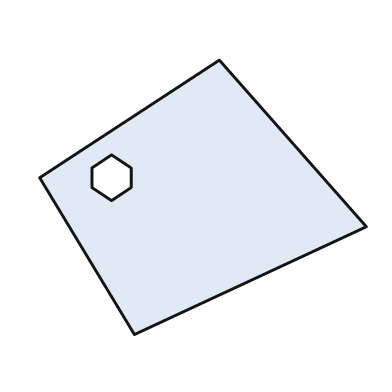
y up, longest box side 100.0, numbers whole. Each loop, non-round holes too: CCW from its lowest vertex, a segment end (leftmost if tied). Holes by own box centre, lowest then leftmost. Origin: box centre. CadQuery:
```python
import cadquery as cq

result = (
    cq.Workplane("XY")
    .moveTo(-21.0, -42.0)
    .lineTo(50.0, -9.0)
    .lineTo(5.0, 42.0)
    .lineTo(-50.0, 6.0)
    .close()
    .moveTo(-28.0, -1.0)
    .lineTo(-22.0, 3.0)
    .lineTo(-22.0, 9.0)
    .lineTo(-28.0, 13.0)
    .lineTo(-34.0, 9.0)
    .lineTo(-34.0, 3.0)
    .close()
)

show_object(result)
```